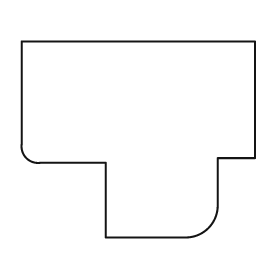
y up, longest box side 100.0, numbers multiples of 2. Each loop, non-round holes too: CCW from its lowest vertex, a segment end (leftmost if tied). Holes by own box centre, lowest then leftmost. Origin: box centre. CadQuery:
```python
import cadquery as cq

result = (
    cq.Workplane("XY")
    .moveTo(-14.0, -42.0)
    .lineTo(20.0, -42.0)
    .threePointArc((30.0, -38.0), (34.0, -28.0))
    .lineTo(34.0, -8.0)
    .lineTo(50.0, -8.0)
    .lineTo(50.0, 42.0)
    .lineTo(-50.0, 42.0)
    .lineTo(-50.0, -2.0)
    .threePointArc((-48.0, -8.0), (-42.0, -10.0))
    .lineTo(-14.0, -10.0)
    .close()
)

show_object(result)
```